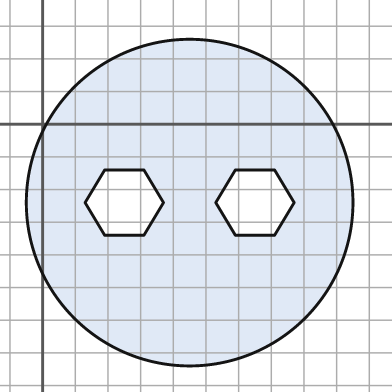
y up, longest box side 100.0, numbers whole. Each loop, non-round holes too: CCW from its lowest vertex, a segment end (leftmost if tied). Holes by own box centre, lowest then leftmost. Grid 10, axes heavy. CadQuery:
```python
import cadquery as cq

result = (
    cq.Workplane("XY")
    .moveTo(45.0, -24.0)
    .circle(50.0)
    .moveTo(19.0, -34.0)
    .lineTo(31.0, -34.0)
    .lineTo(37.0, -24.0)
    .lineTo(31.0, -14.0)
    .lineTo(19.0, -14.0)
    .lineTo(13.0, -24.0)
    .close()
    .moveTo(59.0, -34.0)
    .lineTo(71.0, -34.0)
    .lineTo(77.0, -24.0)
    .lineTo(71.0, -14.0)
    .lineTo(59.0, -14.0)
    .lineTo(53.0, -24.0)
    .close()
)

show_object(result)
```